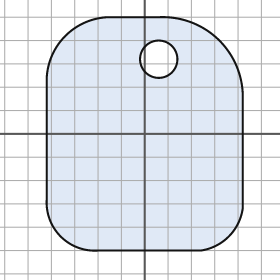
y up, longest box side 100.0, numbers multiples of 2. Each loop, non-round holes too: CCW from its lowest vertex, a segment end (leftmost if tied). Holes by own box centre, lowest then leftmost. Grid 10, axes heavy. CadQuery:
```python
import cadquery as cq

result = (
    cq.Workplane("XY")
    .moveTo(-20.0, -50.0)
    .lineTo(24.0, -50.0)
    .threePointArc((36.0, -44.0), (42.0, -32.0))
    .lineTo(42.0, 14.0)
    .threePointArc((32.0, 40.0), (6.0, 50.0))
    .lineTo(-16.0, 50.0)
    .threePointArc((-34.0, 42.0), (-42.0, 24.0))
    .lineTo(-42.0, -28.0)
    .threePointArc((-36.0, -44.0), (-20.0, -50.0))
    .close()
    .moveTo(6.0, 32.0)
    .circle(8.0)
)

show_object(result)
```